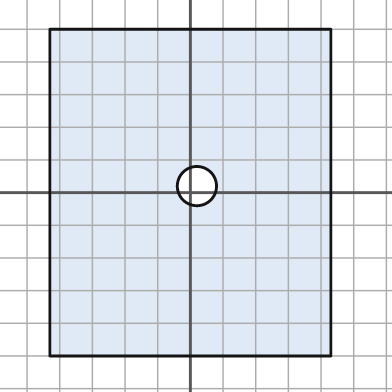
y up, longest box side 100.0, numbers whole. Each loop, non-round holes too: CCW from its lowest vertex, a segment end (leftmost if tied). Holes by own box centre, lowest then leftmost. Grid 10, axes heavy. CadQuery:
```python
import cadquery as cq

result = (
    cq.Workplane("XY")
    .moveTo(-43.0, -50.0)
    .lineTo(43.0, -50.0)
    .lineTo(43.0, 50.0)
    .lineTo(-43.0, 50.0)
    .close()
    .moveTo(2.0, 2.0)
    .circle(6.0)
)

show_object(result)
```